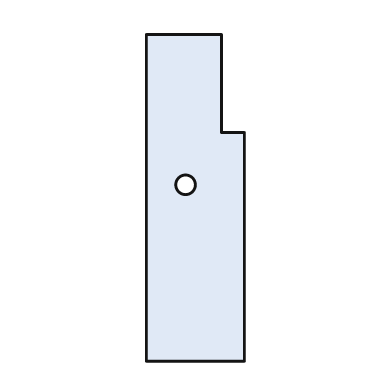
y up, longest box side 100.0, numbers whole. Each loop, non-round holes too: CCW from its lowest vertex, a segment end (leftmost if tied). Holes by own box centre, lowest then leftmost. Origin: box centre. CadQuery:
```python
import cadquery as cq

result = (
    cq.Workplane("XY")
    .moveTo(-15.0, -50.0)
    .lineTo(15.0, -50.0)
    .lineTo(15.0, 20.0)
    .lineTo(8.0, 20.0)
    .lineTo(8.0, 50.0)
    .lineTo(-15.0, 50.0)
    .close()
    .moveTo(-3.0, 4.0)
    .circle(3.0)
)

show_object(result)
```